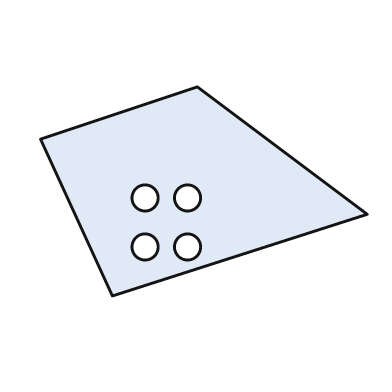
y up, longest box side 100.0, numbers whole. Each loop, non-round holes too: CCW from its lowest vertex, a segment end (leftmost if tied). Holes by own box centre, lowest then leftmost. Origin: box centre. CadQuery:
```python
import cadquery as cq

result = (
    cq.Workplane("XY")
    .moveTo(-28.0, -32.0)
    .lineTo(50.0, -7.0)
    .lineTo(-2.0, 32.0)
    .lineTo(-50.0, 16.0)
    .close()
    .moveTo(-18.0, -17.0)
    .circle(4.0)
    .moveTo(-5.0, -17.0)
    .circle(4.0)
    .moveTo(-18.0, -2.0)
    .circle(4.0)
    .moveTo(-5.0, -2.0)
    .circle(4.0)
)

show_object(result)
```